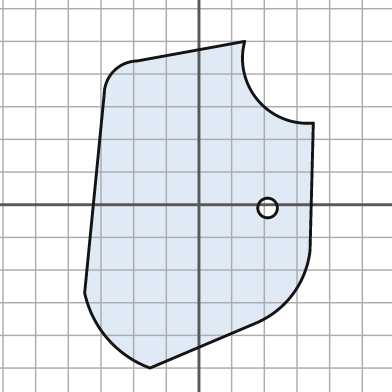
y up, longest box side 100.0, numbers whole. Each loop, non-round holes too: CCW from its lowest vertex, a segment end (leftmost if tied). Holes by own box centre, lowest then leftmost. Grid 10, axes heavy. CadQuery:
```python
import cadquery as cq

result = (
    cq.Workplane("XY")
    .moveTo(-15.0, -50.0)
    .lineTo(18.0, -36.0)
    .threePointArc((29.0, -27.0), (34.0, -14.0))
    .lineTo(35.0, 25.0)
    .threePointArc((18.0, 32.0), (14.0, 50.0))
    .lineTo(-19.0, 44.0)
    .threePointArc((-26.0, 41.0), (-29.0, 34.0))
    .lineTo(-35.0, -27.0)
    .threePointArc((-28.0, -41.0), (-15.0, -50.0))
    .close()
    .moveTo(21.0, -1.0)
    .circle(3.0)
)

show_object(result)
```